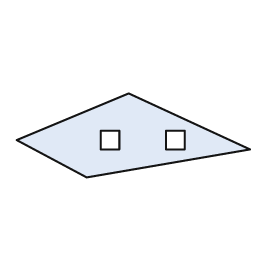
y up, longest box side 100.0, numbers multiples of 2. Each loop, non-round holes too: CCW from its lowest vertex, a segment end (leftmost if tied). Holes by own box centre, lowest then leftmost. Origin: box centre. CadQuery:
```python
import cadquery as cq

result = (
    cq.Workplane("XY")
    .moveTo(-20.0, -18.0)
    .lineTo(50.0, -6.0)
    .lineTo(-2.0, 18.0)
    .lineTo(-50.0, -2.0)
    .close()
    .moveTo(-14.0, -6.0)
    .lineTo(-6.0, -6.0)
    .lineTo(-6.0, 2.0)
    .lineTo(-14.0, 2.0)
    .close()
    .moveTo(14.0, -6.0)
    .lineTo(22.0, -6.0)
    .lineTo(22.0, 2.0)
    .lineTo(14.0, 2.0)
    .close()
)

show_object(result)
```